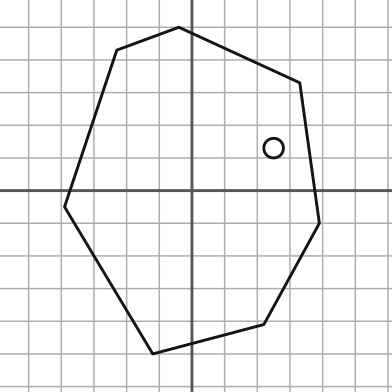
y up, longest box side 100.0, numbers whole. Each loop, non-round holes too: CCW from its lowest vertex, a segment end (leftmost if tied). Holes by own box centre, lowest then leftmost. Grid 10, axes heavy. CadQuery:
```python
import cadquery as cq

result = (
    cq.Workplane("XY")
    .moveTo(-12.0, -50.0)
    .lineTo(22.0, -41.0)
    .lineTo(39.0, -10.0)
    .lineTo(33.0, 33.0)
    .lineTo(-4.0, 50.0)
    .lineTo(-23.0, 43.0)
    .lineTo(-39.0, -5.0)
    .close()
    .moveTo(25.0, 13.0)
    .circle(3.0)
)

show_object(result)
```